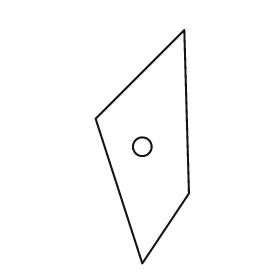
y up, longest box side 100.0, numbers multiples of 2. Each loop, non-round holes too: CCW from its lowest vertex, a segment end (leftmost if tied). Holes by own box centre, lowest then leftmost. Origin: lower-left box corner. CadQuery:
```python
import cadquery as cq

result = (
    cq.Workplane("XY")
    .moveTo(20.0, 0.0)
    .lineTo(40.0, 30.0)
    .lineTo(38.0, 100.0)
    .lineTo(0.0, 62.0)
    .close()
    .moveTo(20.0, 50.0)
    .circle(4.0)
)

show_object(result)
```